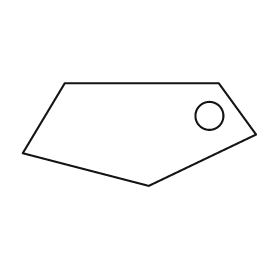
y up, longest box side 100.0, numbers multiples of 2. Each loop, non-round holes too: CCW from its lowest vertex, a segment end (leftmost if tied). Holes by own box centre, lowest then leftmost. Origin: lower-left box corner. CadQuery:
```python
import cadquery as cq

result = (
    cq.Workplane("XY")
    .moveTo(54.0, 0.0)
    .lineTo(100.0, 22.0)
    .lineTo(84.0, 44.0)
    .lineTo(18.0, 44.0)
    .lineTo(0.0, 14.0)
    .close()
    .moveTo(80.0, 30.0)
    .circle(6.0)
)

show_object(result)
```